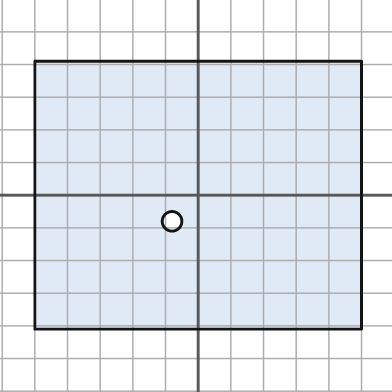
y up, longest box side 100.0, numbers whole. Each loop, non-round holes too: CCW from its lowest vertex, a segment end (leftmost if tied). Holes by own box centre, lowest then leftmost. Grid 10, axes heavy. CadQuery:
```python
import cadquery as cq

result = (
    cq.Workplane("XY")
    .moveTo(-50.0, -41.0)
    .lineTo(50.0, -41.0)
    .lineTo(50.0, 41.0)
    .lineTo(-50.0, 41.0)
    .close()
    .moveTo(-8.0, -8.0)
    .circle(3.0)
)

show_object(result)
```